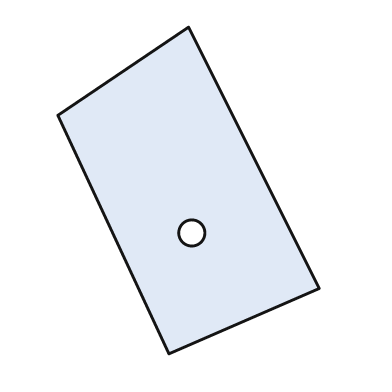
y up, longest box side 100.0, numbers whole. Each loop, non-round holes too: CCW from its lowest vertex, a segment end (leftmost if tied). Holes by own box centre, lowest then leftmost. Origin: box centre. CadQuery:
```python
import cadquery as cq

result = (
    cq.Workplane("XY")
    .moveTo(-6.0, -50.0)
    .lineTo(40.0, -30.0)
    .lineTo(0.0, 50.0)
    .lineTo(-40.0, 23.0)
    .close()
    .moveTo(1.0, -13.0)
    .circle(4.0)
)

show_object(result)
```